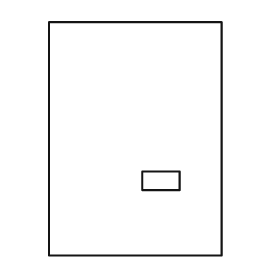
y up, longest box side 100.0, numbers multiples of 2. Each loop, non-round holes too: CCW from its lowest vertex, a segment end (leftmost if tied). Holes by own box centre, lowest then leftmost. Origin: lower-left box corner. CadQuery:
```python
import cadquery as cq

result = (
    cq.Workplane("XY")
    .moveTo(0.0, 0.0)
    .lineTo(74.0, 0.0)
    .lineTo(74.0, 100.0)
    .lineTo(0.0, 100.0)
    .close()
    .moveTo(40.0, 28.0)
    .lineTo(56.0, 28.0)
    .lineTo(56.0, 36.0)
    .lineTo(40.0, 36.0)
    .close()
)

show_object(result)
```